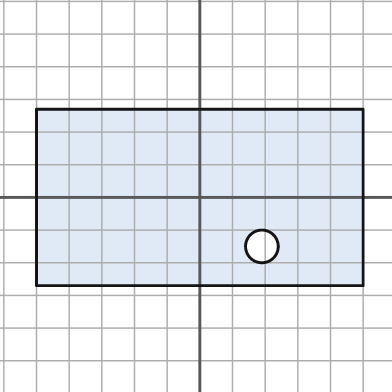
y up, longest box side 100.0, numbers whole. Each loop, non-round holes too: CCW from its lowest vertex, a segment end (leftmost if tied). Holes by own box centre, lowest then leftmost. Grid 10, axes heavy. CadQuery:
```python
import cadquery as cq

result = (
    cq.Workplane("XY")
    .moveTo(-50.0, -27.0)
    .lineTo(50.0, -27.0)
    .lineTo(50.0, 27.0)
    .lineTo(-50.0, 27.0)
    .close()
    .moveTo(19.0, -15.0)
    .circle(5.0)
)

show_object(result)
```